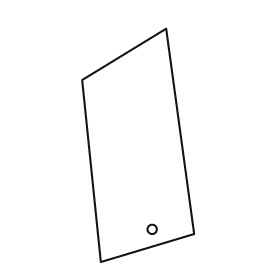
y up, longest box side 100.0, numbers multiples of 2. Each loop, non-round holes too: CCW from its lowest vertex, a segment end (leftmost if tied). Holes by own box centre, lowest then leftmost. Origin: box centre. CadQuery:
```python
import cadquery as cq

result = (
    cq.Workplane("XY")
    .moveTo(-16.0, -50.0)
    .lineTo(24.0, -38.0)
    .lineTo(12.0, 50.0)
    .lineTo(-24.0, 28.0)
    .close()
    .moveTo(6.0, -36.0)
    .circle(2.0)
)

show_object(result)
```